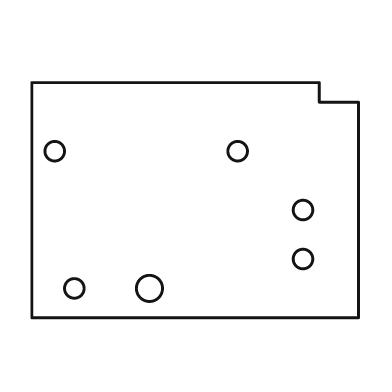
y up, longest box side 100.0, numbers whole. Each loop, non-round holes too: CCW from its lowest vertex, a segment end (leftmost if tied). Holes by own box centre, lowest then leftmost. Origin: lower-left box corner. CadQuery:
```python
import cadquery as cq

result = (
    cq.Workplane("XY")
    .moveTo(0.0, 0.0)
    .lineTo(100.0, 0.0)
    .lineTo(100.0, 66.0)
    .lineTo(88.0, 66.0)
    .lineTo(88.0, 72.0)
    .lineTo(0.0, 72.0)
    .close()
    .moveTo(13.0, 9.0)
    .circle(3.0)
    .moveTo(36.0, 9.0)
    .circle(4.0)
    .moveTo(83.0, 18.0)
    .circle(3.0)
    .moveTo(83.0, 33.0)
    .circle(3.0)
    .moveTo(7.0, 51.0)
    .circle(3.0)
    .moveTo(63.0, 51.0)
    .circle(3.0)
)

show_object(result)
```